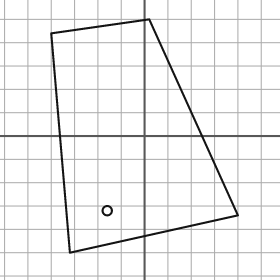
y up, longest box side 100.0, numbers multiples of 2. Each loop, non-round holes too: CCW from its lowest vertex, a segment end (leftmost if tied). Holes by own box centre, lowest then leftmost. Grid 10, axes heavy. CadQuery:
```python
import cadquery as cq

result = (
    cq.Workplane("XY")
    .moveTo(-32.0, -50.0)
    .lineTo(40.0, -34.0)
    .lineTo(2.0, 50.0)
    .lineTo(-40.0, 44.0)
    .close()
    .moveTo(-16.0, -32.0)
    .circle(2.0)
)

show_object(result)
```